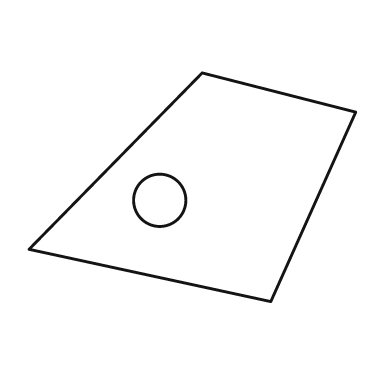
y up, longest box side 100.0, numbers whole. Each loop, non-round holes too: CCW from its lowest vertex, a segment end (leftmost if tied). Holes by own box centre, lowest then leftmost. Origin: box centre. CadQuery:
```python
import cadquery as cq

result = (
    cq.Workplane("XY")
    .moveTo(24.0, -35.0)
    .lineTo(50.0, 23.0)
    .lineTo(3.0, 35.0)
    .lineTo(-50.0, -19.0)
    .close()
    .moveTo(-10.0, -4.0)
    .circle(8.0)
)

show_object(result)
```